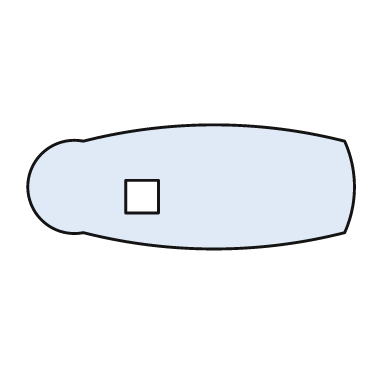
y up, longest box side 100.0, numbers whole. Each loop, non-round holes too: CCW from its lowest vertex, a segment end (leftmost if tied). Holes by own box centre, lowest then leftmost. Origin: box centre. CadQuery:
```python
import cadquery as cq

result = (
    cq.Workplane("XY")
    .moveTo(-33.0, -14.0)
    .threePointArc((7.0, -19.0), (47.0, -14.0))
    .threePointArc((50.0, 0.0), (47.0, 14.0))
    .threePointArc((7.0, 19.0), (-33.0, 14.0))
    .threePointArc((-50.0, 0.0), (-33.0, -14.0))
    .close()
    .moveTo(-20.0, -8.0)
    .lineTo(-10.0, -8.0)
    .lineTo(-10.0, 2.0)
    .lineTo(-20.0, 2.0)
    .close()
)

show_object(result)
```